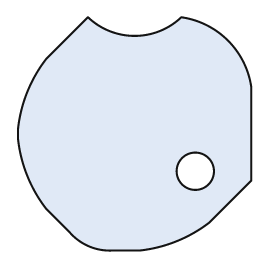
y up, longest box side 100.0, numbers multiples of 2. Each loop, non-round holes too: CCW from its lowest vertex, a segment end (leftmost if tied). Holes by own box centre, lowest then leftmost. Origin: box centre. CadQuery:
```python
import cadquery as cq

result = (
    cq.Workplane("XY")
    .moveTo(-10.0, -50.0)
    .lineTo(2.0, -50.0)
    .threePointArc((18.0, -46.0), (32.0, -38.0))
    .lineTo(50.0, -20.0)
    .lineTo(50.0, 20.0)
    .threePointArc((40.0, 40.0), (20.0, 50.0))
    .threePointArc((0.0, 42.0), (-20.0, 50.0))
    .lineTo(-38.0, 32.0)
    .threePointArc((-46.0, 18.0), (-50.0, 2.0))
    .lineTo(-50.0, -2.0)
    .threePointArc((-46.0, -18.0), (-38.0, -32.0))
    .lineTo(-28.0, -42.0)
    .threePointArc((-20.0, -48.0), (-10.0, -50.0))
    .close()
    .moveTo(26.0, -16.0)
    .circle(8.0)
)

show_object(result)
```